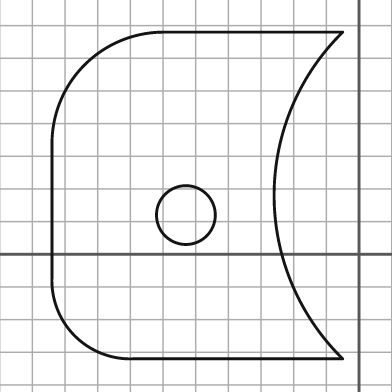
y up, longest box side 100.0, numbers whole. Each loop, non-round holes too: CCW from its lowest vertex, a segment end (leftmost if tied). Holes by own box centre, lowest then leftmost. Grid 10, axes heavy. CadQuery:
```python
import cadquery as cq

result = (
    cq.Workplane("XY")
    .moveTo(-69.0, -32.0)
    .lineTo(-5.0, -32.0)
    .threePointArc((-26.0, 18.0), (-5.0, 68.0))
    .lineTo(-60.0, 68.0)
    .threePointArc((-84.0, 58.0), (-94.0, 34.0))
    .lineTo(-94.0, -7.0)
    .threePointArc((-87.0, -25.0), (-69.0, -32.0))
    .close()
    .moveTo(-53.0, 12.0)
    .circle(9.0)
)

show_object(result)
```